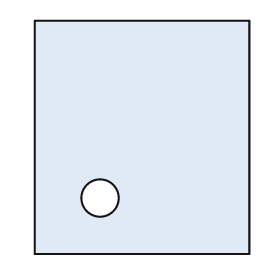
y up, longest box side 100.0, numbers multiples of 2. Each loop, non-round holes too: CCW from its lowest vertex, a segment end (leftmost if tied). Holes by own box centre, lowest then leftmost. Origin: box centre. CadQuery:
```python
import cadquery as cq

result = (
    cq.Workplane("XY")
    .moveTo(-46.0, -50.0)
    .lineTo(46.0, -50.0)
    .lineTo(46.0, 50.0)
    .lineTo(-46.0, 50.0)
    .close()
    .moveTo(-18.0, -26.0)
    .circle(8.0)
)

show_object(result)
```